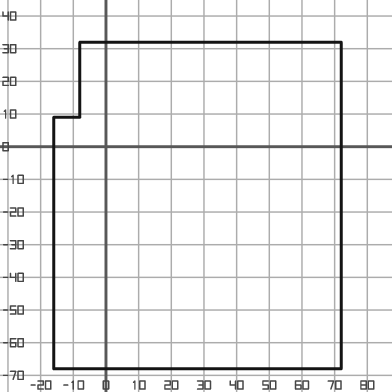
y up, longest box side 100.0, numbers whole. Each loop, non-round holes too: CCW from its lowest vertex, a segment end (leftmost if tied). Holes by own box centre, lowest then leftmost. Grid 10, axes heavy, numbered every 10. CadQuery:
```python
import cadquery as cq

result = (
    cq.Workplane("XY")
    .moveTo(-16.0, -68.0)
    .lineTo(72.0, -68.0)
    .lineTo(72.0, 32.0)
    .lineTo(-8.0, 32.0)
    .lineTo(-8.0, 9.0)
    .lineTo(-16.0, 9.0)
    .close()
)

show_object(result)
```